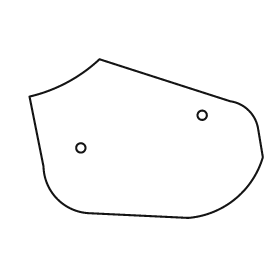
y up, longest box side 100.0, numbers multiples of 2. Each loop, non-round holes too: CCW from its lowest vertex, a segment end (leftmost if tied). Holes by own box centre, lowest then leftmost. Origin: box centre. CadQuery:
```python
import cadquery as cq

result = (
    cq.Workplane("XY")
    .moveTo(18.0, -34.0)
    .threePointArc((38.0, -26.0), (50.0, -8.0))
    .lineTo(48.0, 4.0)
    .threePointArc((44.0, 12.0), (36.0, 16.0))
    .lineTo(-20.0, 34.0)
    .threePointArc((-34.0, 24.0), (-50.0, 18.0))
    .lineTo(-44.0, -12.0)
    .threePointArc((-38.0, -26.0), (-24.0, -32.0))
    .close()
    .moveTo(-28.0, -4.0)
    .circle(2.0)
    .moveTo(24.0, 10.0)
    .circle(2.0)
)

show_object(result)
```